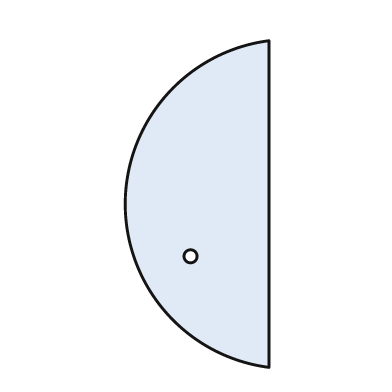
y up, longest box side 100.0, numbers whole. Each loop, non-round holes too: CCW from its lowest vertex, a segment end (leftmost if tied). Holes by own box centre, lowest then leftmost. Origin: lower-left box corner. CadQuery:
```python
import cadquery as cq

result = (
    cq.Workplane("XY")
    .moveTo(44.0, 0.0)
    .lineTo(44.0, 100.0)
    .threePointArc((0.0, 50.0), (44.0, 0.0))
    .close()
    .moveTo(20.0, 34.0)
    .circle(2.0)
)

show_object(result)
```